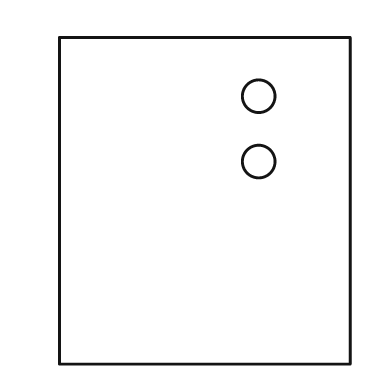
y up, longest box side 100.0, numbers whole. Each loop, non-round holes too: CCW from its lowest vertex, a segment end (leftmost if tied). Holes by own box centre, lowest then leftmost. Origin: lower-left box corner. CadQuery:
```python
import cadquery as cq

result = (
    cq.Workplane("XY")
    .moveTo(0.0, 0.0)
    .lineTo(89.0, 0.0)
    .lineTo(89.0, 100.0)
    .lineTo(0.0, 100.0)
    .close()
    .moveTo(61.0, 62.0)
    .circle(5.0)
    .moveTo(61.0, 82.0)
    .circle(5.0)
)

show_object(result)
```